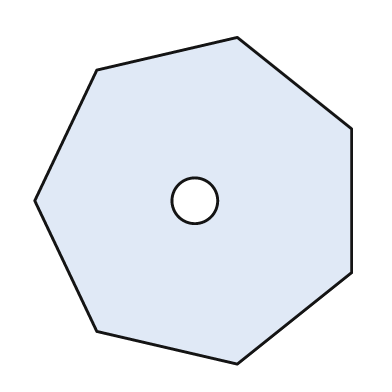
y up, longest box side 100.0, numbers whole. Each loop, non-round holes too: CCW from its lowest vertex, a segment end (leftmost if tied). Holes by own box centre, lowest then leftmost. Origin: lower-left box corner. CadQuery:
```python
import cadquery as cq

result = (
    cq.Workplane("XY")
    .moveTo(62.0, 0.0)
    .lineTo(97.0, 28.0)
    .lineTo(97.0, 72.0)
    .lineTo(62.0, 100.0)
    .lineTo(19.0, 90.0)
    .lineTo(0.0, 50.0)
    .lineTo(19.0, 10.0)
    .close()
    .moveTo(49.0, 50.0)
    .circle(7.0)
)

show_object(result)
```